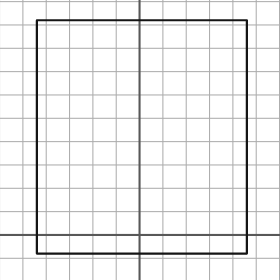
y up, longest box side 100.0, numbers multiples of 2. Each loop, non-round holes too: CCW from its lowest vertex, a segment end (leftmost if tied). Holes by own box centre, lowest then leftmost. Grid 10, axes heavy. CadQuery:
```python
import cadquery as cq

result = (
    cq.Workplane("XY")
    .moveTo(-44.0, -8.0)
    .lineTo(46.0, -8.0)
    .lineTo(46.0, 92.0)
    .lineTo(-44.0, 92.0)
    .close()
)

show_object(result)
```